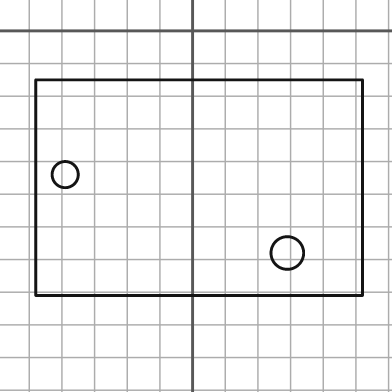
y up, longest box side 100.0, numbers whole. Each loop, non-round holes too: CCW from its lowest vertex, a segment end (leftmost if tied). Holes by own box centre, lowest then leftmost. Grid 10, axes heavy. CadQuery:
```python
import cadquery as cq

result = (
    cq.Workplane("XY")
    .moveTo(-48.0, -81.0)
    .lineTo(52.0, -81.0)
    .lineTo(52.0, -15.0)
    .lineTo(-48.0, -15.0)
    .close()
    .moveTo(29.0, -68.0)
    .circle(5.0)
    .moveTo(-39.0, -44.0)
    .circle(4.0)
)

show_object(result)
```